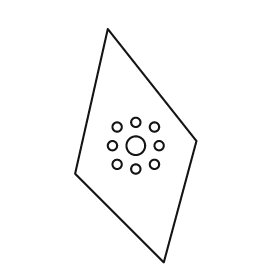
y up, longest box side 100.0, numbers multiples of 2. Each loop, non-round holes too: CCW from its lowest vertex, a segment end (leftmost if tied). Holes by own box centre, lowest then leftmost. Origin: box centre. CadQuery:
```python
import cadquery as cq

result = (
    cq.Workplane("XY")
    .moveTo(12.0, -50.0)
    .lineTo(26.0, 2.0)
    .lineTo(-12.0, 50.0)
    .lineTo(-26.0, -12.0)
    .close()
    .moveTo(0.0, -10.0)
    .circle(2.0)
    .moveTo(-8.0, -8.0)
    .circle(2.0)
    .moveTo(8.0, -8.0)
    .circle(2.0)
    .moveTo(-10.0, 0.0)
    .circle(2.0)
    .moveTo(0.0, 0.0)
    .circle(4.0)
    .moveTo(10.0, 0.0)
    .circle(2.0)
    .moveTo(-8.0, 8.0)
    .circle(2.0)
    .moveTo(8.0, 8.0)
    .circle(2.0)
    .moveTo(0.0, 10.0)
    .circle(2.0)
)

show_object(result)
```